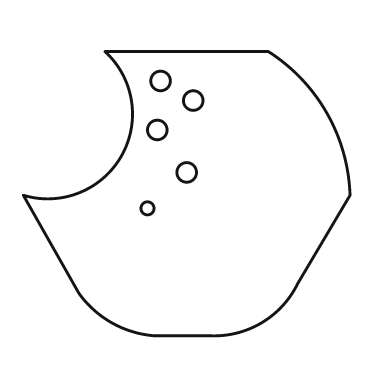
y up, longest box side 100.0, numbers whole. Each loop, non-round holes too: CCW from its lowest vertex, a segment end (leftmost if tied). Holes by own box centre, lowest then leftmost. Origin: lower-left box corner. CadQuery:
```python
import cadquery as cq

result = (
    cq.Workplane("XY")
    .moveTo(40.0, 0.0)
    .lineTo(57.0, 0.0)
    .threePointArc((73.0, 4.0), (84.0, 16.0))
    .lineTo(100.0, 43.0)
    .threePointArc((93.0, 68.0), (75.0, 87.0))
    .lineTo(25.0, 87.0)
    .threePointArc((30.0, 55.0), (0.0, 43.0))
    .lineTo(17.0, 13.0)
    .threePointArc((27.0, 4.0), (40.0, 0.0))
    .close()
    .moveTo(38.0, 39.0)
    .circle(2.0)
    .moveTo(50.0, 50.0)
    .circle(3.0)
    .moveTo(41.0, 63.0)
    .circle(3.0)
    .moveTo(52.0, 72.0)
    .circle(3.0)
    .moveTo(42.0, 78.0)
    .circle(3.0)
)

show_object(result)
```